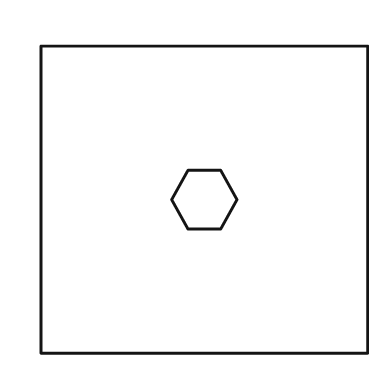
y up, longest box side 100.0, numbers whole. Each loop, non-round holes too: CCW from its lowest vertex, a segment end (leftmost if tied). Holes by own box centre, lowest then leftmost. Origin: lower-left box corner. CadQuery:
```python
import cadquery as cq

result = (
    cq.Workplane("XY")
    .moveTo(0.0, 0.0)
    .lineTo(100.0, 0.0)
    .lineTo(100.0, 94.0)
    .lineTo(0.0, 94.0)
    .close()
    .moveTo(45.0, 38.0)
    .lineTo(55.0, 38.0)
    .lineTo(60.0, 47.0)
    .lineTo(55.0, 56.0)
    .lineTo(45.0, 56.0)
    .lineTo(40.0, 47.0)
    .close()
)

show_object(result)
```